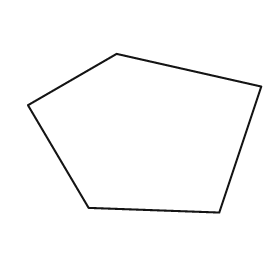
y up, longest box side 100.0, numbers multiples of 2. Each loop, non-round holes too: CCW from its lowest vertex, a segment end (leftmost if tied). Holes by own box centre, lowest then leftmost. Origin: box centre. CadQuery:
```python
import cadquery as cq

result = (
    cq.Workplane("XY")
    .moveTo(32.0, -34.0)
    .lineTo(50.0, 20.0)
    .lineTo(-12.0, 34.0)
    .lineTo(-50.0, 12.0)
    .lineTo(-24.0, -32.0)
    .close()
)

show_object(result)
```